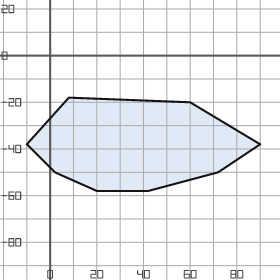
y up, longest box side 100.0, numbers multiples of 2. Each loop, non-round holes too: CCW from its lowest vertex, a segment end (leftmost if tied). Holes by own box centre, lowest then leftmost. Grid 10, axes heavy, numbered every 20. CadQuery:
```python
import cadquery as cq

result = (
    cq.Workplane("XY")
    .moveTo(20.0, -58.0)
    .lineTo(42.0, -58.0)
    .lineTo(72.0, -50.0)
    .lineTo(90.0, -38.0)
    .lineTo(60.0, -20.0)
    .lineTo(8.0, -18.0)
    .lineTo(-10.0, -38.0)
    .lineTo(2.0, -50.0)
    .close()
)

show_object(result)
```